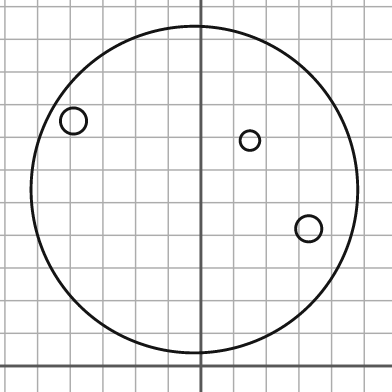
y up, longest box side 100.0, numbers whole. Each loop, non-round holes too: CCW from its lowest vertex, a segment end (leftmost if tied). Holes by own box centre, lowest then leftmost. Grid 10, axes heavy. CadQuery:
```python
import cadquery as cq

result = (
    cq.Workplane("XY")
    .moveTo(-2.0, 54.0)
    .circle(50.0)
    .moveTo(33.0, 42.0)
    .circle(4.0)
    .moveTo(15.0, 69.0)
    .circle(3.0)
    .moveTo(-39.0, 75.0)
    .circle(4.0)
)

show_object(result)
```